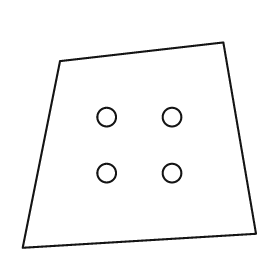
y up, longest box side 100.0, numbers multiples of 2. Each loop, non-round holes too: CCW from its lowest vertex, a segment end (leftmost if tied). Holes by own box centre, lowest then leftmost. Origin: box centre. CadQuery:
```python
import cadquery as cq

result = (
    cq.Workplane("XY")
    .moveTo(-50.0, -44.0)
    .lineTo(50.0, -38.0)
    .lineTo(36.0, 44.0)
    .lineTo(-34.0, 36.0)
    .close()
    .moveTo(-14.0, -12.0)
    .circle(4.0)
    .moveTo(14.0, -12.0)
    .circle(4.0)
    .moveTo(-14.0, 12.0)
    .circle(4.0)
    .moveTo(14.0, 12.0)
    .circle(4.0)
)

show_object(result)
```